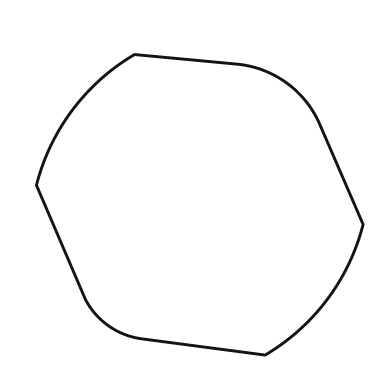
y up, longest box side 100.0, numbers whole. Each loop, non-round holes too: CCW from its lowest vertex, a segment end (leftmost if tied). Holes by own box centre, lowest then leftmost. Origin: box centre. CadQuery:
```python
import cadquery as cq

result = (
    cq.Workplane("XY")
    .moveTo(20.0, -46.0)
    .threePointArc((39.0, -29.0), (50.0, -6.0))
    .lineTo(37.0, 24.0)
    .threePointArc((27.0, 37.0), (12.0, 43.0))
    .lineTo(-20.0, 46.0)
    .threePointArc((-39.0, 29.0), (-50.0, 6.0))
    .lineTo(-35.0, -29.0)
    .threePointArc((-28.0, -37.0), (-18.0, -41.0))
    .close()
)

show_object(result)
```